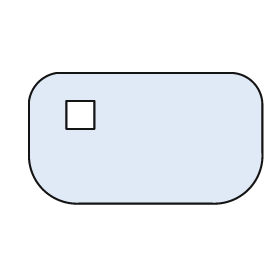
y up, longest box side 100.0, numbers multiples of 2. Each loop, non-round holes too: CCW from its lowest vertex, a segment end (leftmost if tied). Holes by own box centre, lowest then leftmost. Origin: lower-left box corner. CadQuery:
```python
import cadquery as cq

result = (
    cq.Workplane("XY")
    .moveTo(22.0, 0.0)
    .lineTo(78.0, 0.0)
    .threePointArc((94.0, 6.0), (100.0, 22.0))
    .lineTo(100.0, 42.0)
    .threePointArc((96.0, 52.0), (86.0, 56.0))
    .lineTo(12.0, 56.0)
    .threePointArc((4.0, 52.0), (0.0, 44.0))
    .lineTo(0.0, 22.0)
    .threePointArc((6.0, 6.0), (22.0, 0.0))
    .close()
    .moveTo(16.0, 32.0)
    .lineTo(28.0, 32.0)
    .lineTo(28.0, 44.0)
    .lineTo(16.0, 44.0)
    .close()
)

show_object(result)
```